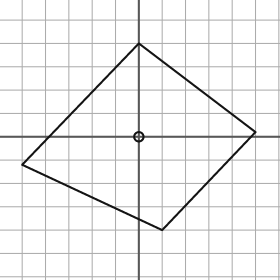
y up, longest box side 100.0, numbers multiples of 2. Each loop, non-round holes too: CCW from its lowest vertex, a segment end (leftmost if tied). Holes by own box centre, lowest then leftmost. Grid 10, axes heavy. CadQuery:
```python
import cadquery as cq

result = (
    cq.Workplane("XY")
    .moveTo(10.0, -40.0)
    .lineTo(50.0, 2.0)
    .lineTo(0.0, 40.0)
    .lineTo(-50.0, -12.0)
    .close()
    .moveTo(0.0, 0.0)
    .circle(2.0)
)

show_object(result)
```